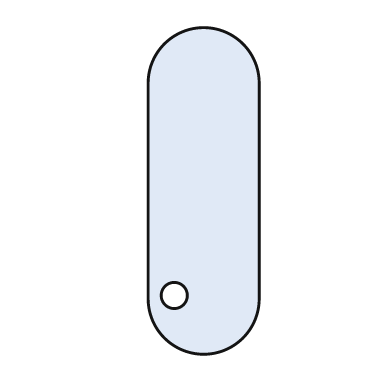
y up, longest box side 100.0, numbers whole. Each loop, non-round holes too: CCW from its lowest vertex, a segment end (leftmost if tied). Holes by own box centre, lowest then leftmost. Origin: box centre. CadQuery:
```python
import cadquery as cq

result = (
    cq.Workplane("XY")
    .moveTo(-17.0, -33.0)
    .threePointArc((0.0, -50.0), (17.0, -33.0))
    .lineTo(17.0, 33.0)
    .threePointArc((0.0, 50.0), (-17.0, 33.0))
    .close()
    .moveTo(-9.0, -32.0)
    .circle(4.0)
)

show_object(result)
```